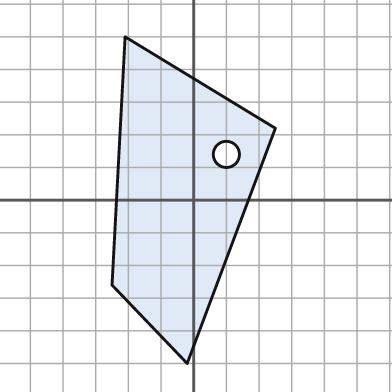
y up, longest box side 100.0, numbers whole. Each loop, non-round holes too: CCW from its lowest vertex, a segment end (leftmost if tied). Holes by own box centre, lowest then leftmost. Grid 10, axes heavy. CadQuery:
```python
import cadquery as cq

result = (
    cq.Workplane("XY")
    .moveTo(-2.0, -50.0)
    .lineTo(25.0, 22.0)
    .lineTo(-21.0, 50.0)
    .lineTo(-25.0, -26.0)
    .close()
    .moveTo(10.0, 14.0)
    .circle(4.0)
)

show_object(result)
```